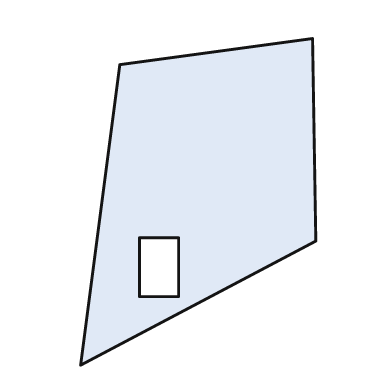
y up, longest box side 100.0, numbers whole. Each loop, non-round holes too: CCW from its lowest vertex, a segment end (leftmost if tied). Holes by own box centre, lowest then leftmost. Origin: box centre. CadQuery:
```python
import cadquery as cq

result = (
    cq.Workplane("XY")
    .moveTo(-36.0, -50.0)
    .lineTo(36.0, -12.0)
    .lineTo(35.0, 50.0)
    .lineTo(-24.0, 42.0)
    .close()
    .moveTo(-18.0, -29.0)
    .lineTo(-6.0, -29.0)
    .lineTo(-6.0, -11.0)
    .lineTo(-18.0, -11.0)
    .close()
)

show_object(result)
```